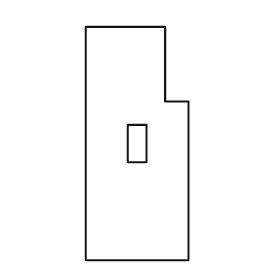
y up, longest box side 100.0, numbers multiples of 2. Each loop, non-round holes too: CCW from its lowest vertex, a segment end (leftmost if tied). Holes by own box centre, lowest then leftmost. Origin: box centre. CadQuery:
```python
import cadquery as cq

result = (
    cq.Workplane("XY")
    .moveTo(-22.0, -50.0)
    .lineTo(22.0, -50.0)
    .lineTo(22.0, 18.0)
    .lineTo(12.0, 18.0)
    .lineTo(12.0, 50.0)
    .lineTo(-22.0, 50.0)
    .close()
    .moveTo(-4.0, -8.0)
    .lineTo(4.0, -8.0)
    .lineTo(4.0, 8.0)
    .lineTo(-4.0, 8.0)
    .close()
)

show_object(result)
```